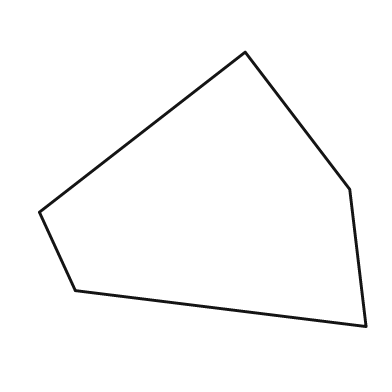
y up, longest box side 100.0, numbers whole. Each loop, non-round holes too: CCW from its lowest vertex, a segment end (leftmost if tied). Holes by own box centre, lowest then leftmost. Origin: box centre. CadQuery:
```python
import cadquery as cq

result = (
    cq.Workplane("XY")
    .moveTo(50.0, -42.0)
    .lineTo(45.0, 0.0)
    .lineTo(13.0, 42.0)
    .lineTo(-50.0, -7.0)
    .lineTo(-39.0, -31.0)
    .close()
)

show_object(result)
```